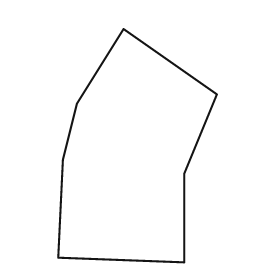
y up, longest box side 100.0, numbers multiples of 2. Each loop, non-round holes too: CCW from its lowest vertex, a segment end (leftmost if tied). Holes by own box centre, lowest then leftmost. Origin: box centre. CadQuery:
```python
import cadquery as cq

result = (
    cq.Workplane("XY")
    .moveTo(20.0, -50.0)
    .lineTo(20.0, -12.0)
    .lineTo(34.0, 22.0)
    .lineTo(-6.0, 50.0)
    .lineTo(-26.0, 18.0)
    .lineTo(-32.0, -6.0)
    .lineTo(-34.0, -48.0)
    .close()
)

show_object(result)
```